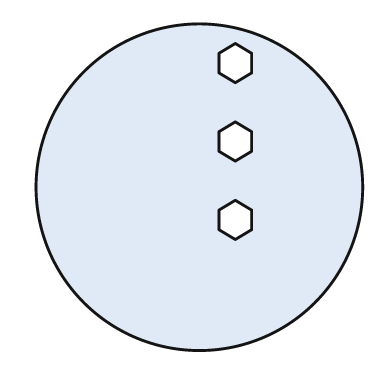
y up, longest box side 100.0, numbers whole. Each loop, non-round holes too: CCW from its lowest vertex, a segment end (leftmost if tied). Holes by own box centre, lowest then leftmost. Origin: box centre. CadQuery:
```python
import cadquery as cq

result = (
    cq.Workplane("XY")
    .moveTo(0.0, 0.0)
    .circle(50.0)
    .moveTo(11.0, -16.0)
    .lineTo(16.0, -13.0)
    .lineTo(16.0, -7.0)
    .lineTo(11.0, -4.0)
    .lineTo(6.0, -7.0)
    .lineTo(6.0, -13.0)
    .close()
    .moveTo(11.0, 8.0)
    .lineTo(16.0, 11.0)
    .lineTo(16.0, 17.0)
    .lineTo(11.0, 20.0)
    .lineTo(6.0, 17.0)
    .lineTo(6.0, 11.0)
    .close()
    .moveTo(11.0, 32.0)
    .lineTo(16.0, 35.0)
    .lineTo(16.0, 41.0)
    .lineTo(11.0, 44.0)
    .lineTo(6.0, 41.0)
    .lineTo(6.0, 35.0)
    .close()
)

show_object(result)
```